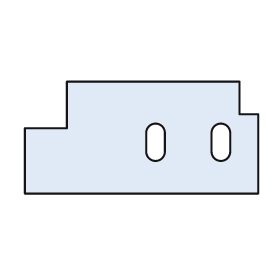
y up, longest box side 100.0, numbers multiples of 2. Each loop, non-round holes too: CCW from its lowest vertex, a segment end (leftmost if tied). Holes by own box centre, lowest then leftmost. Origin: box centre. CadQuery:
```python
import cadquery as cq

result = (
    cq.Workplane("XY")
    .moveTo(-50.0, -24.0)
    .lineTo(50.0, -24.0)
    .lineTo(50.0, 10.0)
    .lineTo(42.0, 10.0)
    .lineTo(42.0, 24.0)
    .lineTo(-32.0, 24.0)
    .lineTo(-32.0, 4.0)
    .lineTo(-50.0, 4.0)
    .close()
    .moveTo(2.0, -6.0)
    .threePointArc((6.0, -10.0), (10.0, -6.0))
    .lineTo(10.0, 2.0)
    .threePointArc((6.0, 6.0), (2.0, 2.0))
    .close()
    .moveTo(30.0, -6.0)
    .threePointArc((34.0, -10.0), (38.0, -6.0))
    .lineTo(38.0, 2.0)
    .threePointArc((34.0, 6.0), (30.0, 2.0))
    .close()
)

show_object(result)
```